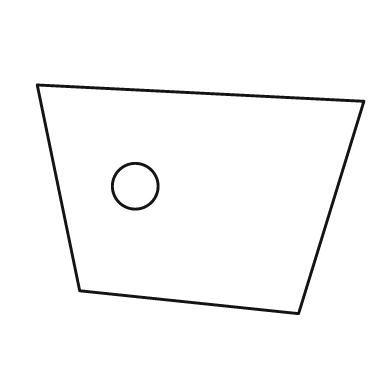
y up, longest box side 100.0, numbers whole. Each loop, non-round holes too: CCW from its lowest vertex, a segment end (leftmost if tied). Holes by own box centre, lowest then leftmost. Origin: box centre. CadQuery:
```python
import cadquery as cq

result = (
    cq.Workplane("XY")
    .moveTo(30.0, -35.0)
    .lineTo(50.0, 30.0)
    .lineTo(-50.0, 35.0)
    .lineTo(-37.0, -28.0)
    .close()
    .moveTo(-20.0, 4.0)
    .circle(7.0)
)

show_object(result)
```